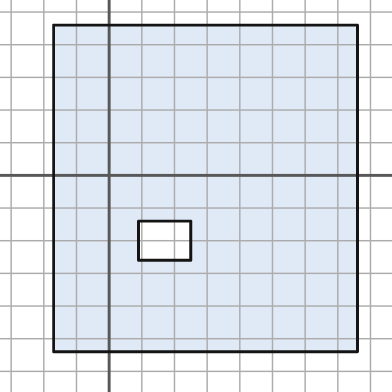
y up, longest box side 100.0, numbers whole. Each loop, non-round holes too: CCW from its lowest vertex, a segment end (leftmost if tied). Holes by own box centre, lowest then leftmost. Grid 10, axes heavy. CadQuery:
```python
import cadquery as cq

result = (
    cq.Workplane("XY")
    .moveTo(-17.0, -54.0)
    .lineTo(76.0, -54.0)
    .lineTo(76.0, 46.0)
    .lineTo(-17.0, 46.0)
    .close()
    .moveTo(9.0, -26.0)
    .lineTo(25.0, -26.0)
    .lineTo(25.0, -14.0)
    .lineTo(9.0, -14.0)
    .close()
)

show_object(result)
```